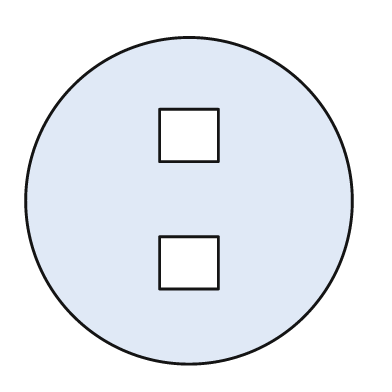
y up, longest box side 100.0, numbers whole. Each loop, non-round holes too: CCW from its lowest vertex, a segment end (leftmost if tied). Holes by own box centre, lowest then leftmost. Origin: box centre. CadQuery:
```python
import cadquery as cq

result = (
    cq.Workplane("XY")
    .moveTo(0.0, 0.0)
    .circle(50.0)
    .moveTo(-9.0, -27.0)
    .lineTo(9.0, -27.0)
    .lineTo(9.0, -11.0)
    .lineTo(-9.0, -11.0)
    .close()
    .moveTo(-9.0, 12.0)
    .lineTo(9.0, 12.0)
    .lineTo(9.0, 28.0)
    .lineTo(-9.0, 28.0)
    .close()
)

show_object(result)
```